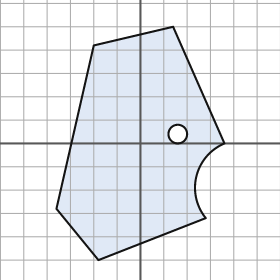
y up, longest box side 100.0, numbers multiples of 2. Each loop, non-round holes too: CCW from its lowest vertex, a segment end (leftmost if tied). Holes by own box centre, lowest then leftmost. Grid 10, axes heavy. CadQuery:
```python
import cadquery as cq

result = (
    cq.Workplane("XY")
    .moveTo(-18.0, -50.0)
    .lineTo(28.0, -32.0)
    .threePointArc((24.0, -14.0), (36.0, 0.0))
    .lineTo(14.0, 50.0)
    .lineTo(-20.0, 42.0)
    .lineTo(-36.0, -28.0)
    .close()
    .moveTo(16.0, 4.0)
    .circle(4.0)
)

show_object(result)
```